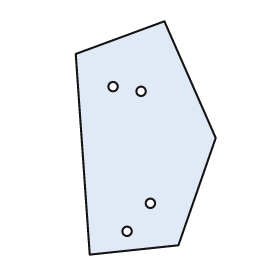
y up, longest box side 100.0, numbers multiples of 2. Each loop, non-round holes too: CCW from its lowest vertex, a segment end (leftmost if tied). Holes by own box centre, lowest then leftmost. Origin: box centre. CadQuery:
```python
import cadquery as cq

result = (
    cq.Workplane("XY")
    .moveTo(-24.0, -50.0)
    .lineTo(14.0, -46.0)
    .lineTo(30.0, 0.0)
    .lineTo(8.0, 50.0)
    .lineTo(-30.0, 36.0)
    .close()
    .moveTo(-8.0, -40.0)
    .circle(2.0)
    .moveTo(2.0, -28.0)
    .circle(2.0)
    .moveTo(-2.0, 20.0)
    .circle(2.0)
    .moveTo(-14.0, 22.0)
    .circle(2.0)
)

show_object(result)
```